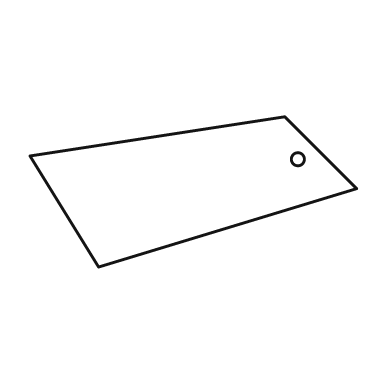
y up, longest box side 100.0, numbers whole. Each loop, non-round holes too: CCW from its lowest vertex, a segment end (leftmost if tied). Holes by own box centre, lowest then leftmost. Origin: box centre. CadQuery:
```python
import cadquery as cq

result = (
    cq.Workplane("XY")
    .moveTo(-29.0, -23.0)
    .lineTo(50.0, 1.0)
    .lineTo(28.0, 23.0)
    .lineTo(-50.0, 11.0)
    .close()
    .moveTo(32.0, 10.0)
    .circle(2.0)
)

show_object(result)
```